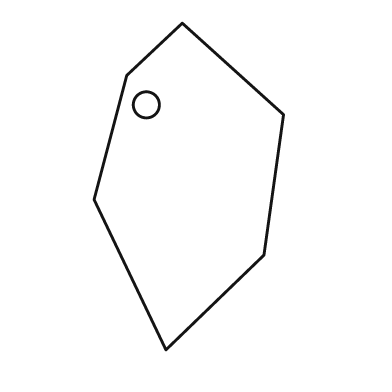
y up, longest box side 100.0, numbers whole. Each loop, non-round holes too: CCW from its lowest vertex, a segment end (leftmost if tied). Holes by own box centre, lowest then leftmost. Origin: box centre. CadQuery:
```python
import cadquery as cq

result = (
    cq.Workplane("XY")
    .moveTo(-7.0, -50.0)
    .lineTo(23.0, -21.0)
    .lineTo(29.0, 22.0)
    .lineTo(-2.0, 50.0)
    .lineTo(-19.0, 34.0)
    .lineTo(-29.0, -4.0)
    .close()
    .moveTo(-13.0, 25.0)
    .circle(4.0)
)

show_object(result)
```